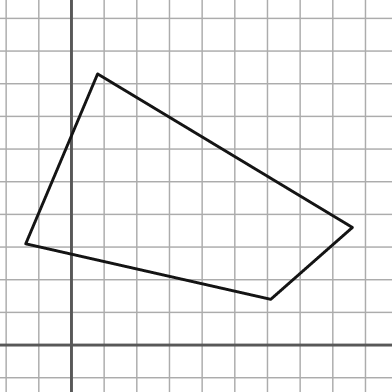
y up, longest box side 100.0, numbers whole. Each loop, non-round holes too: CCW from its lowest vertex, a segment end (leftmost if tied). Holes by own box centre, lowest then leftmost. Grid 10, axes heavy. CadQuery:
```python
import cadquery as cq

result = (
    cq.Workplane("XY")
    .moveTo(61.0, 14.0)
    .lineTo(86.0, 36.0)
    .lineTo(8.0, 83.0)
    .lineTo(-14.0, 31.0)
    .close()
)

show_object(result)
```